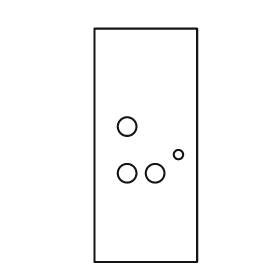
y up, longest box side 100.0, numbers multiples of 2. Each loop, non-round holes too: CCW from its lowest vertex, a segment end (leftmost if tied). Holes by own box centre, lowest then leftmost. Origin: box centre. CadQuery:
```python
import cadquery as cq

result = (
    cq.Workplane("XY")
    .moveTo(-22.0, -50.0)
    .lineTo(22.0, -50.0)
    .lineTo(22.0, 50.0)
    .lineTo(-22.0, 50.0)
    .close()
    .moveTo(-8.0, -12.0)
    .circle(4.0)
    .moveTo(4.0, -12.0)
    .circle(4.0)
    .moveTo(14.0, -4.0)
    .circle(2.0)
    .moveTo(-8.0, 8.0)
    .circle(4.0)
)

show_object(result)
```